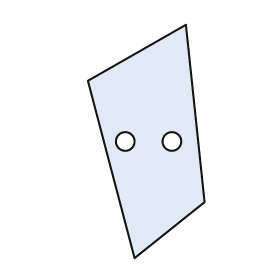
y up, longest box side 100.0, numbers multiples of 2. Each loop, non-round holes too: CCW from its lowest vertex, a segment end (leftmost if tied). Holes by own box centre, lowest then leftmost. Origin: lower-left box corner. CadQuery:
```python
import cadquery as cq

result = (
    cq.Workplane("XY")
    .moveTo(20.0, 0.0)
    .lineTo(50.0, 24.0)
    .lineTo(42.0, 100.0)
    .lineTo(0.0, 76.0)
    .close()
    .moveTo(16.0, 50.0)
    .circle(4.0)
    .moveTo(36.0, 50.0)
    .circle(4.0)
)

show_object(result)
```